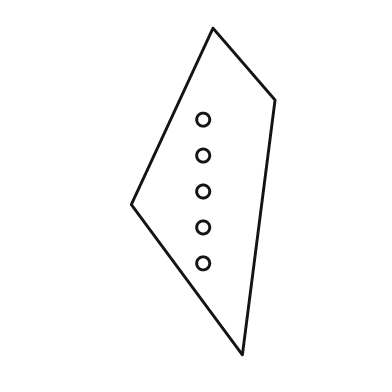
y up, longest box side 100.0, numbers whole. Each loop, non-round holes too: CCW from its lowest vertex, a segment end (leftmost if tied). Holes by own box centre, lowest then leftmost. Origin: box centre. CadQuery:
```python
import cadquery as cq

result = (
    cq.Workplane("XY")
    .moveTo(12.0, -50.0)
    .lineTo(22.0, 28.0)
    .lineTo(3.0, 50.0)
    .lineTo(-22.0, -4.0)
    .close()
    .moveTo(0.0, -22.0)
    .circle(2.0)
    .moveTo(0.0, -11.0)
    .circle(2.0)
    .moveTo(0.0, 0.0)
    .circle(2.0)
    .moveTo(0.0, 11.0)
    .circle(2.0)
    .moveTo(0.0, 22.0)
    .circle(2.0)
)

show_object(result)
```